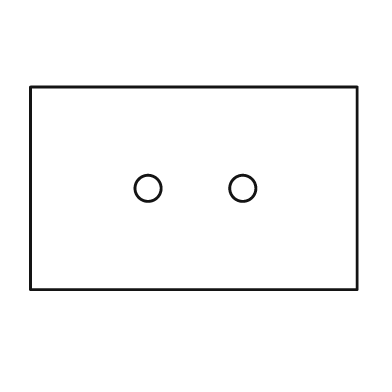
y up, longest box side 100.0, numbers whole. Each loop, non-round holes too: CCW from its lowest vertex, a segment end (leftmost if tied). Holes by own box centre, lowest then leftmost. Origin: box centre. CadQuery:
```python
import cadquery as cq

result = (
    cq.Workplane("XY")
    .moveTo(-50.0, -31.0)
    .lineTo(50.0, -31.0)
    .lineTo(50.0, 31.0)
    .lineTo(-50.0, 31.0)
    .close()
    .moveTo(-14.0, 0.0)
    .circle(4.0)
    .moveTo(15.0, 0.0)
    .circle(4.0)
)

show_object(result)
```